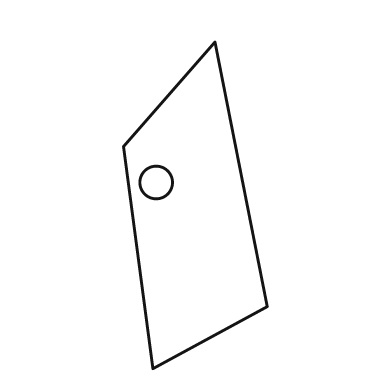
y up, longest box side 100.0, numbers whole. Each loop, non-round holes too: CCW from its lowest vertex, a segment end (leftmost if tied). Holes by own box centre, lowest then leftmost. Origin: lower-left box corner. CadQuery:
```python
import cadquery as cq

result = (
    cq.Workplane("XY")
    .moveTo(9.0, 0.0)
    .lineTo(44.0, 19.0)
    .lineTo(28.0, 100.0)
    .lineTo(0.0, 68.0)
    .close()
    .moveTo(10.0, 57.0)
    .circle(5.0)
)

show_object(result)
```